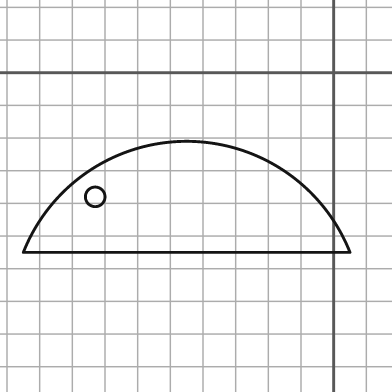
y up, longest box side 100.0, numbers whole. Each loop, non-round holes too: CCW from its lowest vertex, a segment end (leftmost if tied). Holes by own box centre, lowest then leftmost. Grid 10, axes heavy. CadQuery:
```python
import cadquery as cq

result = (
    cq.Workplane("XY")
    .moveTo(-95.0, -55.0)
    .lineTo(5.0, -55.0)
    .threePointArc((-45.0, -21.0), (-95.0, -55.0))
    .close()
    .moveTo(-73.0, -38.0)
    .circle(3.0)
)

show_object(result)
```